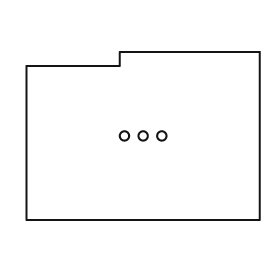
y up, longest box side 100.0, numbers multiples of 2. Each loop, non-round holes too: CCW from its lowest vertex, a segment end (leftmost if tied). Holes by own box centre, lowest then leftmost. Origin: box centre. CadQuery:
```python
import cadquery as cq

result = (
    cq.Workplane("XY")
    .moveTo(-50.0, -36.0)
    .lineTo(50.0, -36.0)
    .lineTo(50.0, 36.0)
    .lineTo(-10.0, 36.0)
    .lineTo(-10.0, 30.0)
    .lineTo(-50.0, 30.0)
    .close()
    .moveTo(-8.0, 0.0)
    .circle(2.0)
    .moveTo(0.0, 0.0)
    .circle(2.0)
    .moveTo(8.0, 0.0)
    .circle(2.0)
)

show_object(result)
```